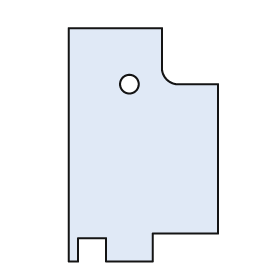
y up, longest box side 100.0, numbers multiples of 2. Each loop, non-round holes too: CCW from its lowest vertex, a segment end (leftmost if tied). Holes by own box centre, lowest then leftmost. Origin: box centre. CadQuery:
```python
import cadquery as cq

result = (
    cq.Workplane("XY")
    .moveTo(-32.0, -50.0)
    .lineTo(-28.0, -50.0)
    .lineTo(-28.0, -40.0)
    .lineTo(-16.0, -40.0)
    .lineTo(-16.0, -50.0)
    .lineTo(4.0, -50.0)
    .lineTo(4.0, -38.0)
    .lineTo(32.0, -38.0)
    .lineTo(32.0, 26.0)
    .lineTo(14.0, 26.0)
    .threePointArc((10.0, 28.0), (8.0, 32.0))
    .lineTo(8.0, 50.0)
    .lineTo(-32.0, 50.0)
    .close()
    .moveTo(-6.0, 26.0)
    .circle(4.0)
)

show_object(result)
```